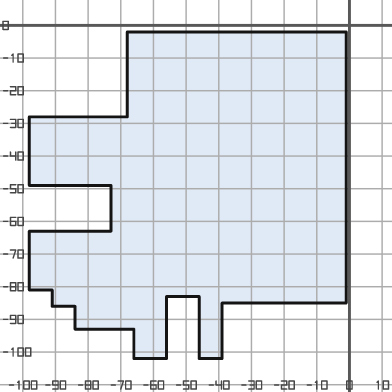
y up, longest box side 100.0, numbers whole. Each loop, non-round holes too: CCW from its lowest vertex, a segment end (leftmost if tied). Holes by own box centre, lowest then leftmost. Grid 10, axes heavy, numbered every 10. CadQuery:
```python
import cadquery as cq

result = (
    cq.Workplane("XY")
    .moveTo(-66.0, -102.0)
    .lineTo(-56.0, -102.0)
    .lineTo(-56.0, -83.0)
    .lineTo(-46.0, -83.0)
    .lineTo(-46.0, -102.0)
    .lineTo(-39.0, -102.0)
    .lineTo(-39.0, -85.0)
    .lineTo(-1.0, -85.0)
    .lineTo(-1.0, -2.0)
    .lineTo(-68.0, -2.0)
    .lineTo(-68.0, -28.0)
    .lineTo(-98.0, -28.0)
    .lineTo(-98.0, -49.0)
    .lineTo(-73.0, -49.0)
    .lineTo(-73.0, -63.0)
    .lineTo(-98.0, -63.0)
    .lineTo(-98.0, -81.0)
    .lineTo(-91.0, -81.0)
    .lineTo(-91.0, -86.0)
    .lineTo(-84.0, -86.0)
    .lineTo(-84.0, -93.0)
    .lineTo(-66.0, -93.0)
    .close()
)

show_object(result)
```